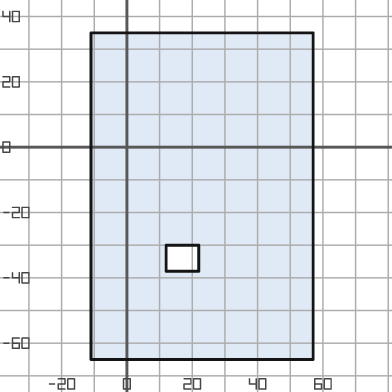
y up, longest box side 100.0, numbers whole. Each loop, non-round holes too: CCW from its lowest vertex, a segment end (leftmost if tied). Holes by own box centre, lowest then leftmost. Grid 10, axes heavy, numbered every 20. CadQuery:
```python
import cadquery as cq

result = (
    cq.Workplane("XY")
    .moveTo(-11.0, -65.0)
    .lineTo(57.0, -65.0)
    .lineTo(57.0, 35.0)
    .lineTo(-11.0, 35.0)
    .close()
    .moveTo(12.0, -38.0)
    .lineTo(22.0, -38.0)
    .lineTo(22.0, -30.0)
    .lineTo(12.0, -30.0)
    .close()
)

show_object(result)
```